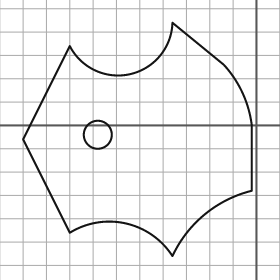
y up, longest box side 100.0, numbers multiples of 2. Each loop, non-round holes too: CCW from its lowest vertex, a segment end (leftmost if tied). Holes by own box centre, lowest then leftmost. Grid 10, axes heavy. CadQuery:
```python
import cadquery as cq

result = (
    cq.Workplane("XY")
    .moveTo(-36.0, -56.0)
    .threePointArc((-22.0, -38.0), (-2.0, -28.0))
    .lineTo(-2.0, 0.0)
    .threePointArc((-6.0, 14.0), (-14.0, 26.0))
    .lineTo(-36.0, 44.0)
    .threePointArc((-54.0, 22.0), (-80.0, 34.0))
    .lineTo(-100.0, -6.0)
    .lineTo(-80.0, -46.0)
    .threePointArc((-56.0, -42.0), (-36.0, -56.0))
    .close()
    .moveTo(-68.0, -4.0)
    .circle(6.0)
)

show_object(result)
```